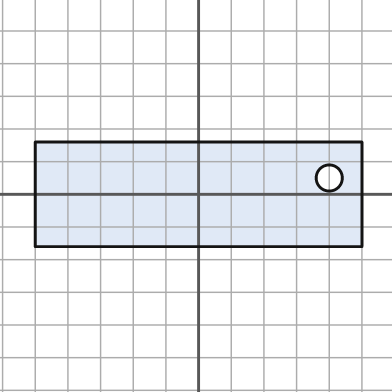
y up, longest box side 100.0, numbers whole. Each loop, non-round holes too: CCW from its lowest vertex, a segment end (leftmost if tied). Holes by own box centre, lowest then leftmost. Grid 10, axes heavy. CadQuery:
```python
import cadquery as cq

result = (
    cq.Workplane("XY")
    .moveTo(-50.0, -16.0)
    .lineTo(50.0, -16.0)
    .lineTo(50.0, 16.0)
    .lineTo(-50.0, 16.0)
    .close()
    .moveTo(40.0, 5.0)
    .circle(4.0)
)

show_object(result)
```